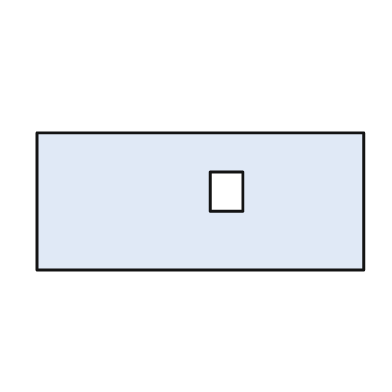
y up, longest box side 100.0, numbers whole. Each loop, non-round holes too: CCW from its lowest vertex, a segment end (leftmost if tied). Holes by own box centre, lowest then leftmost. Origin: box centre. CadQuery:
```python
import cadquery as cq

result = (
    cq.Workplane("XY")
    .moveTo(-50.0, -21.0)
    .lineTo(50.0, -21.0)
    .lineTo(50.0, 21.0)
    .lineTo(-50.0, 21.0)
    .close()
    .moveTo(3.0, -3.0)
    .lineTo(13.0, -3.0)
    .lineTo(13.0, 9.0)
    .lineTo(3.0, 9.0)
    .close()
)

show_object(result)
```